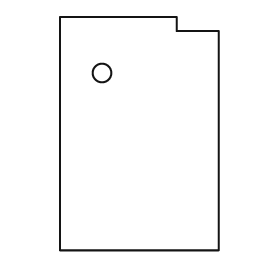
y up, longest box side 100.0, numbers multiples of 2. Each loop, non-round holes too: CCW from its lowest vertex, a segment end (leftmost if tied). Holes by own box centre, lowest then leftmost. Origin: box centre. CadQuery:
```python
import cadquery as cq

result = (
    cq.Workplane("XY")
    .moveTo(-34.0, -50.0)
    .lineTo(34.0, -50.0)
    .lineTo(34.0, 44.0)
    .lineTo(16.0, 44.0)
    .lineTo(16.0, 50.0)
    .lineTo(-34.0, 50.0)
    .close()
    .moveTo(-16.0, 26.0)
    .circle(4.0)
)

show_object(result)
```